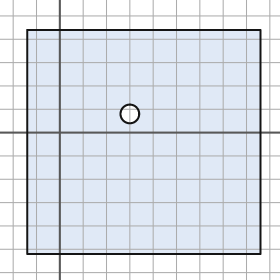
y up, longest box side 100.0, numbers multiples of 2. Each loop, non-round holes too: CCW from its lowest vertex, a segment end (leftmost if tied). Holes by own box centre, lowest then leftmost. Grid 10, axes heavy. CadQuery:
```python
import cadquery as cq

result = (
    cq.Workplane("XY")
    .moveTo(-14.0, -52.0)
    .lineTo(86.0, -52.0)
    .lineTo(86.0, 44.0)
    .lineTo(-14.0, 44.0)
    .close()
    .moveTo(30.0, 8.0)
    .circle(4.0)
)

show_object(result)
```